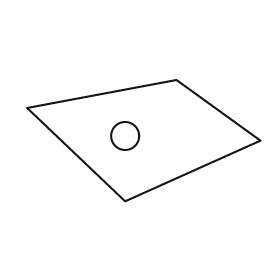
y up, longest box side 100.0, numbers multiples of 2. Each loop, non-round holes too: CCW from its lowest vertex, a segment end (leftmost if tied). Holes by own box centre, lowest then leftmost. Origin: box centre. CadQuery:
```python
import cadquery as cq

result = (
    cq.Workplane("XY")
    .moveTo(-8.0, -26.0)
    .lineTo(50.0, 0.0)
    .lineTo(14.0, 26.0)
    .lineTo(-50.0, 14.0)
    .close()
    .moveTo(-8.0, 2.0)
    .circle(6.0)
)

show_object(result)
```